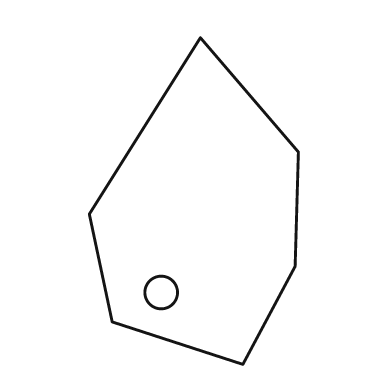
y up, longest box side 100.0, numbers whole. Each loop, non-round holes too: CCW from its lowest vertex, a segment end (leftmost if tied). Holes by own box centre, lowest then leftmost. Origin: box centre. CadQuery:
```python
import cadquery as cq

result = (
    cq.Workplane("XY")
    .moveTo(15.0, -50.0)
    .lineTo(31.0, -20.0)
    .lineTo(32.0, 15.0)
    .lineTo(2.0, 50.0)
    .lineTo(-32.0, -4.0)
    .lineTo(-25.0, -37.0)
    .close()
    .moveTo(-10.0, -28.0)
    .circle(5.0)
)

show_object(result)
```